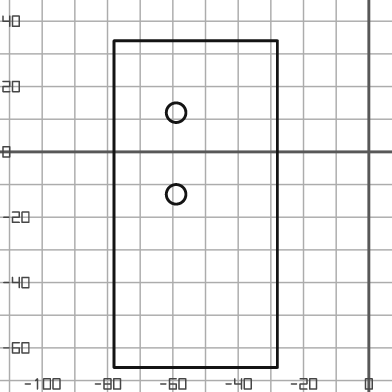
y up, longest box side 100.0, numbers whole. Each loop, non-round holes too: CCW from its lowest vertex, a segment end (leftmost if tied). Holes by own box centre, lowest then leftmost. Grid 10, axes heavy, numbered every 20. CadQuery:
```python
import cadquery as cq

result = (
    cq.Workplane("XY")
    .moveTo(-78.0, -66.0)
    .lineTo(-28.0, -66.0)
    .lineTo(-28.0, 34.0)
    .lineTo(-78.0, 34.0)
    .close()
    .moveTo(-59.0, -13.0)
    .circle(3.0)
    .moveTo(-59.0, 12.0)
    .circle(3.0)
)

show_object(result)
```